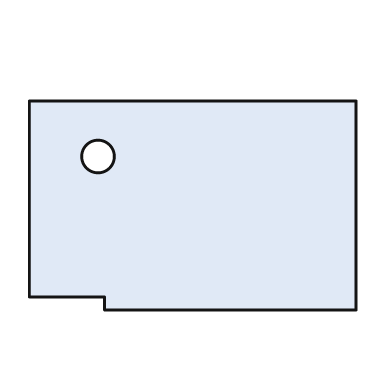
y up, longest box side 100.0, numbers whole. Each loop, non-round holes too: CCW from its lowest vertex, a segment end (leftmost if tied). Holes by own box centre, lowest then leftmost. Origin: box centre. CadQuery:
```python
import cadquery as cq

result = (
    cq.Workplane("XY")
    .moveTo(-27.0, -32.0)
    .lineTo(50.0, -32.0)
    .lineTo(50.0, 32.0)
    .lineTo(-50.0, 32.0)
    .lineTo(-50.0, -28.0)
    .lineTo(-27.0, -28.0)
    .close()
    .moveTo(-29.0, 15.0)
    .circle(5.0)
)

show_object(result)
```